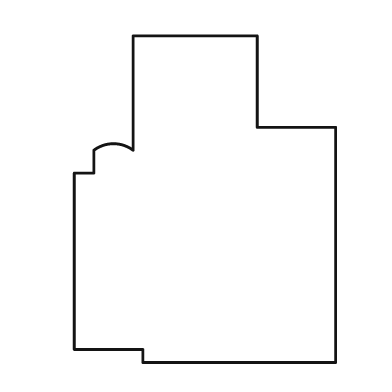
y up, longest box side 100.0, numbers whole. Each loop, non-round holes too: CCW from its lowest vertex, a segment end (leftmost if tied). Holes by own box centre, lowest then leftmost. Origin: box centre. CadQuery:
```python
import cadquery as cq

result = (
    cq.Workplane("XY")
    .moveTo(-19.0, -50.0)
    .lineTo(40.0, -50.0)
    .lineTo(40.0, 22.0)
    .lineTo(16.0, 22.0)
    .lineTo(16.0, 50.0)
    .lineTo(-22.0, 50.0)
    .lineTo(-22.0, 15.0)
    .threePointArc((-28.0, 17.0), (-34.0, 15.0))
    .lineTo(-34.0, 8.0)
    .lineTo(-40.0, 8.0)
    .lineTo(-40.0, -46.0)
    .lineTo(-19.0, -46.0)
    .close()
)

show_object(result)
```